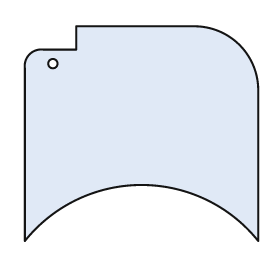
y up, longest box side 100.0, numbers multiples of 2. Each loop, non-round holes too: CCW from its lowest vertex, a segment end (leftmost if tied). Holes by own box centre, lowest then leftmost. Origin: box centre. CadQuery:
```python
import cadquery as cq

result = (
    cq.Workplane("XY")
    .moveTo(-50.0, -46.0)
    .threePointArc((0.0, -22.0), (50.0, -46.0))
    .lineTo(50.0, 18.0)
    .threePointArc((42.0, 38.0), (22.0, 46.0))
    .lineTo(-28.0, 46.0)
    .lineTo(-28.0, 36.0)
    .lineTo(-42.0, 36.0)
    .threePointArc((-48.0, 34.0), (-50.0, 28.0))
    .close()
    .moveTo(-38.0, 30.0)
    .circle(2.0)
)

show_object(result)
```